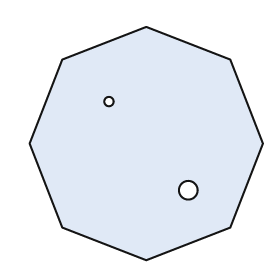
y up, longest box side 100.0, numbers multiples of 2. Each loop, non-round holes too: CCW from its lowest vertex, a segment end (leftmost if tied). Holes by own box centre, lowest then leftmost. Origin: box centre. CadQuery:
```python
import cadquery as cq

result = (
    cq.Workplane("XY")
    .moveTo(0.0, -50.0)
    .lineTo(36.0, -36.0)
    .lineTo(50.0, 0.0)
    .lineTo(36.0, 36.0)
    .lineTo(0.0, 50.0)
    .lineTo(-36.0, 36.0)
    .lineTo(-50.0, 0.0)
    .lineTo(-36.0, -36.0)
    .close()
    .moveTo(18.0, -20.0)
    .circle(4.0)
    .moveTo(-16.0, 18.0)
    .circle(2.0)
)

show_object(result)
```